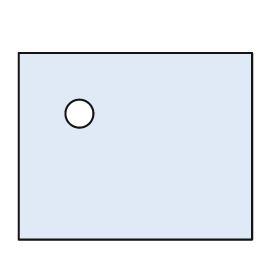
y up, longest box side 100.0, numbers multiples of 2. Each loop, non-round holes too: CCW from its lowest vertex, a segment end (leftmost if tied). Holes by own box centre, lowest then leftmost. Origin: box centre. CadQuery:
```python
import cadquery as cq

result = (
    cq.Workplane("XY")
    .moveTo(-50.0, -40.0)
    .lineTo(50.0, -40.0)
    .lineTo(50.0, 40.0)
    .lineTo(-50.0, 40.0)
    .close()
    .moveTo(-24.0, 14.0)
    .circle(6.0)
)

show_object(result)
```